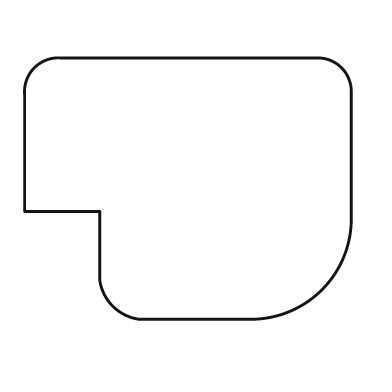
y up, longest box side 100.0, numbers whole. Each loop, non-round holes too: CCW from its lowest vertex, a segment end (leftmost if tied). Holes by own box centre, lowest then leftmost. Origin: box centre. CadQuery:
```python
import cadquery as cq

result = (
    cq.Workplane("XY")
    .moveTo(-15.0, -40.0)
    .lineTo(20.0, -40.0)
    .threePointArc((41.0, -31.0), (50.0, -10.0))
    .lineTo(50.0, 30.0)
    .threePointArc((47.0, 37.0), (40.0, 40.0))
    .lineTo(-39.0, 40.0)
    .threePointArc((-47.0, 37.0), (-50.0, 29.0))
    .lineTo(-50.0, -7.0)
    .lineTo(-27.0, -7.0)
    .lineTo(-27.0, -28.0)
    .threePointArc((-23.0, -36.0), (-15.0, -40.0))
    .close()
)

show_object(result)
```